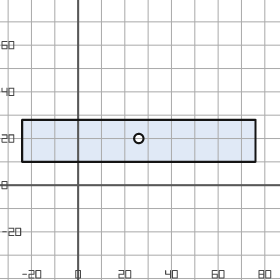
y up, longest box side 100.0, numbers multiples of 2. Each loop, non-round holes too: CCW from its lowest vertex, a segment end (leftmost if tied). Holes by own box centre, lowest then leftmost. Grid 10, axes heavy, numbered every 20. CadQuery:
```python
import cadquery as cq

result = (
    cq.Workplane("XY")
    .moveTo(-24.0, 10.0)
    .lineTo(76.0, 10.0)
    .lineTo(76.0, 28.0)
    .lineTo(-24.0, 28.0)
    .close()
    .moveTo(26.0, 20.0)
    .circle(2.0)
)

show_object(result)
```